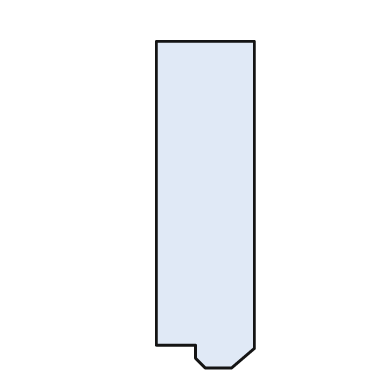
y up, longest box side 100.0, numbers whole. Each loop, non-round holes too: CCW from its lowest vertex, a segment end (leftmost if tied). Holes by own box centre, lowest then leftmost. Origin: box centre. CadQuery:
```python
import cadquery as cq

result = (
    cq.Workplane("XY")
    .moveTo(0.0, -50.0)
    .lineTo(8.0, -50.0)
    .lineTo(15.0, -44.0)
    .lineTo(15.0, 50.0)
    .lineTo(-15.0, 50.0)
    .lineTo(-15.0, -43.0)
    .lineTo(-3.0, -43.0)
    .lineTo(-3.0, -47.0)
    .close()
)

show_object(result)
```